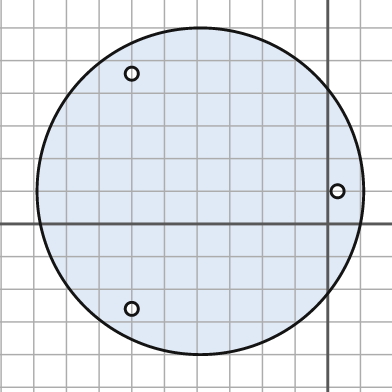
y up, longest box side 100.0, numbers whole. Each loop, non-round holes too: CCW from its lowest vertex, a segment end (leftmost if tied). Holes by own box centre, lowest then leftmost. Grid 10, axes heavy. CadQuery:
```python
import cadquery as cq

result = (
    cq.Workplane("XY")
    .moveTo(-39.0, 10.0)
    .circle(50.0)
    .moveTo(-60.0, -26.0)
    .circle(2.0)
    .moveTo(3.0, 10.0)
    .circle(2.0)
    .moveTo(-60.0, 46.0)
    .circle(2.0)
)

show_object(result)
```